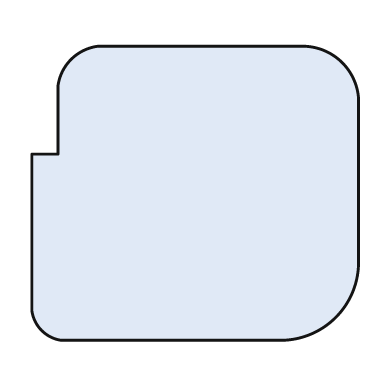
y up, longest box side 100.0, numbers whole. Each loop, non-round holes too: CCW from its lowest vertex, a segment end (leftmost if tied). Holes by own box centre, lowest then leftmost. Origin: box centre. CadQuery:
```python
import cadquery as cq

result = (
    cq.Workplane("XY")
    .moveTo(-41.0, -45.0)
    .lineTo(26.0, -45.0)
    .threePointArc((43.0, -38.0), (50.0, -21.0))
    .lineTo(50.0, 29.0)
    .threePointArc((45.0, 40.0), (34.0, 45.0))
    .lineTo(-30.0, 45.0)
    .threePointArc((-38.0, 41.0), (-42.0, 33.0))
    .lineTo(-42.0, 12.0)
    .lineTo(-50.0, 12.0)
    .lineTo(-50.0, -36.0)
    .threePointArc((-47.0, -42.0), (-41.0, -45.0))
    .close()
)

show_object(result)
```